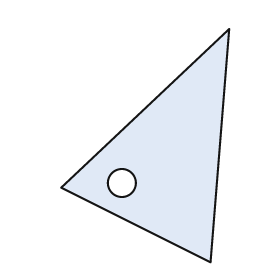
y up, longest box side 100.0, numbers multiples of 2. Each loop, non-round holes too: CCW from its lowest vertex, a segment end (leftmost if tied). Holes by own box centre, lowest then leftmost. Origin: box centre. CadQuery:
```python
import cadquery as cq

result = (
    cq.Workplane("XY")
    .moveTo(28.0, -50.0)
    .lineTo(36.0, 50.0)
    .lineTo(-36.0, -18.0)
    .close()
    .moveTo(-10.0, -16.0)
    .circle(6.0)
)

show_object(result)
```